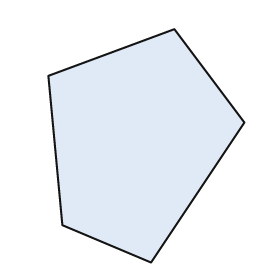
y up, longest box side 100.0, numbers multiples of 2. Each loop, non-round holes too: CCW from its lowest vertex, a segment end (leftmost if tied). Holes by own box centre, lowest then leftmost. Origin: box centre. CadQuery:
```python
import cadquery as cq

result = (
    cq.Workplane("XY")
    .moveTo(2.0, -50.0)
    .lineTo(42.0, 10.0)
    .lineTo(12.0, 50.0)
    .lineTo(-42.0, 30.0)
    .lineTo(-36.0, -34.0)
    .close()
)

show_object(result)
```